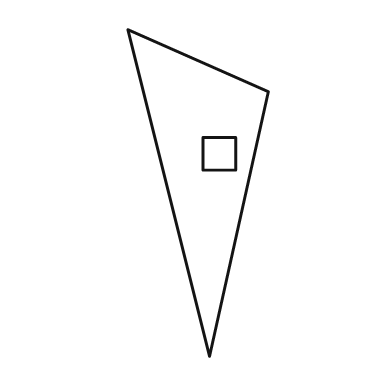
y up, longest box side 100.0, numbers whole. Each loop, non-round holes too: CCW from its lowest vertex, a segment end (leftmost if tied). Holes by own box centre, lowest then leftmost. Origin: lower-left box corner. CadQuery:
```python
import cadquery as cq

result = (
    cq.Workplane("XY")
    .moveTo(25.0, 0.0)
    .lineTo(43.0, 81.0)
    .lineTo(0.0, 100.0)
    .close()
    .moveTo(23.0, 57.0)
    .lineTo(33.0, 57.0)
    .lineTo(33.0, 67.0)
    .lineTo(23.0, 67.0)
    .close()
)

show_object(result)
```